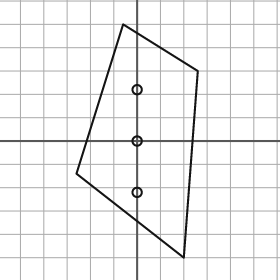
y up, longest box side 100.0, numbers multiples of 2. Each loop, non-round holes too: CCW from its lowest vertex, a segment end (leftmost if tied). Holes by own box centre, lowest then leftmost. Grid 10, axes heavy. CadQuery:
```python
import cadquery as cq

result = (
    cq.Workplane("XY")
    .moveTo(20.0, -50.0)
    .lineTo(26.0, 30.0)
    .lineTo(-6.0, 50.0)
    .lineTo(-26.0, -14.0)
    .close()
    .moveTo(0.0, -22.0)
    .circle(2.0)
    .moveTo(0.0, 0.0)
    .circle(2.0)
    .moveTo(0.0, 22.0)
    .circle(2.0)
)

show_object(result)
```